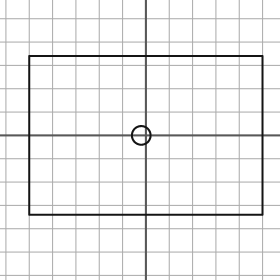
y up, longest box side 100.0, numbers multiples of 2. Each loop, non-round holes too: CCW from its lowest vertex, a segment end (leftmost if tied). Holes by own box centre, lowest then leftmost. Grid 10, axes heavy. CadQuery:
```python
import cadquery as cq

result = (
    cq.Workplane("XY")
    .moveTo(-50.0, -34.0)
    .lineTo(50.0, -34.0)
    .lineTo(50.0, 34.0)
    .lineTo(-50.0, 34.0)
    .close()
    .moveTo(-2.0, 0.0)
    .circle(4.0)
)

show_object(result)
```